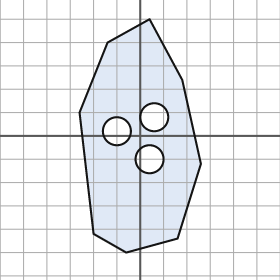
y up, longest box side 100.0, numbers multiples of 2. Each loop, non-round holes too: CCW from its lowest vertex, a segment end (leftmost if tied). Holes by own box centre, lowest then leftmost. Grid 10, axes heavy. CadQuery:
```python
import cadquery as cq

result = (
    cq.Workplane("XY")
    .moveTo(-6.0, -50.0)
    .lineTo(16.0, -44.0)
    .lineTo(26.0, -12.0)
    .lineTo(18.0, 24.0)
    .lineTo(4.0, 50.0)
    .lineTo(-14.0, 40.0)
    .lineTo(-26.0, 10.0)
    .lineTo(-20.0, -42.0)
    .close()
    .moveTo(4.0, -10.0)
    .circle(6.0)
    .moveTo(-10.0, 2.0)
    .circle(6.0)
    .moveTo(6.0, 8.0)
    .circle(6.0)
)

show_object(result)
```